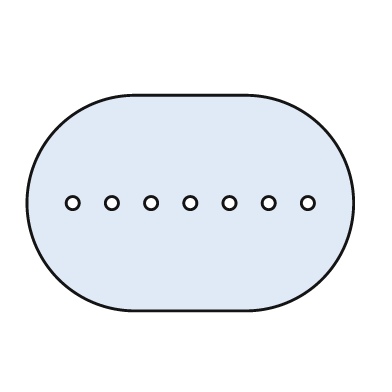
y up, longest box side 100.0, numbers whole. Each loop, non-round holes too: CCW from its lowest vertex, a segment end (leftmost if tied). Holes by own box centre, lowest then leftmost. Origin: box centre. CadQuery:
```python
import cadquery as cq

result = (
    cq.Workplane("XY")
    .moveTo(-17.0, -33.0)
    .lineTo(17.0, -33.0)
    .threePointArc((50.0, 0.0), (17.0, 33.0))
    .lineTo(-17.0, 33.0)
    .threePointArc((-50.0, 0.0), (-17.0, -33.0))
    .close()
    .moveTo(-36.0, 0.0)
    .circle(2.0)
    .moveTo(-24.0, 0.0)
    .circle(2.0)
    .moveTo(-12.0, 0.0)
    .circle(2.0)
    .moveTo(0.0, 0.0)
    .circle(2.0)
    .moveTo(12.0, 0.0)
    .circle(2.0)
    .moveTo(24.0, 0.0)
    .circle(2.0)
    .moveTo(36.0, 0.0)
    .circle(2.0)
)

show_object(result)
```